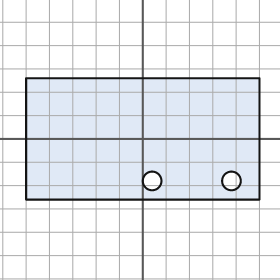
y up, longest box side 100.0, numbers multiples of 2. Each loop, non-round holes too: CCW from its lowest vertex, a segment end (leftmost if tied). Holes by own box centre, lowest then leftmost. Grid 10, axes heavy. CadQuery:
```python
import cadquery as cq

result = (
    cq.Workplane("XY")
    .moveTo(-50.0, -26.0)
    .lineTo(50.0, -26.0)
    .lineTo(50.0, 26.0)
    .lineTo(-50.0, 26.0)
    .close()
    .moveTo(4.0, -18.0)
    .circle(4.0)
    .moveTo(38.0, -18.0)
    .circle(4.0)
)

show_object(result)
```